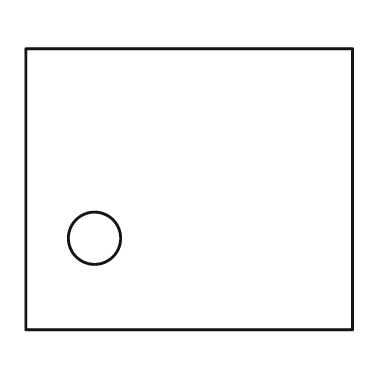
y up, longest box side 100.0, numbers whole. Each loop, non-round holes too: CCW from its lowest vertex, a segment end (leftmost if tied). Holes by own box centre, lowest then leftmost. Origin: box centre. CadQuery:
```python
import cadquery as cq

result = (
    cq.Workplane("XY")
    .moveTo(-50.0, -43.0)
    .lineTo(50.0, -43.0)
    .lineTo(50.0, 43.0)
    .lineTo(-50.0, 43.0)
    .close()
    .moveTo(-29.0, -15.0)
    .circle(8.0)
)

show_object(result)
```